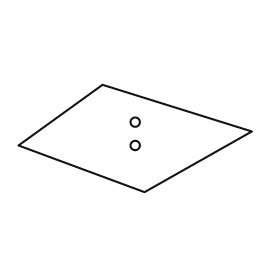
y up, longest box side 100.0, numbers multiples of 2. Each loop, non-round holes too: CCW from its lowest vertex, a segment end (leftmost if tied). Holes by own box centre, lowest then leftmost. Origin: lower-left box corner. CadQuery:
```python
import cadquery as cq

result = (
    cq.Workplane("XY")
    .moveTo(54.0, 0.0)
    .lineTo(100.0, 26.0)
    .lineTo(36.0, 46.0)
    .lineTo(0.0, 20.0)
    .close()
    .moveTo(50.0, 20.0)
    .circle(2.0)
    .moveTo(50.0, 30.0)
    .circle(2.0)
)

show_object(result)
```